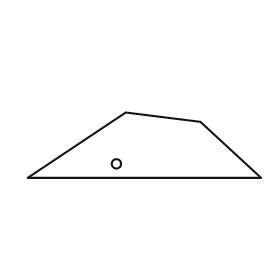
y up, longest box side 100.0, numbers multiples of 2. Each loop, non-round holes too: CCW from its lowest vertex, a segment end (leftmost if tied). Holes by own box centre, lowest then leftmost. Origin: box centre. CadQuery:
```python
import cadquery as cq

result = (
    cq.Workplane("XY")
    .moveTo(-50.0, -14.0)
    .lineTo(50.0, -14.0)
    .lineTo(24.0, 10.0)
    .lineTo(-8.0, 14.0)
    .close()
    .moveTo(-12.0, -8.0)
    .circle(2.0)
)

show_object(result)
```